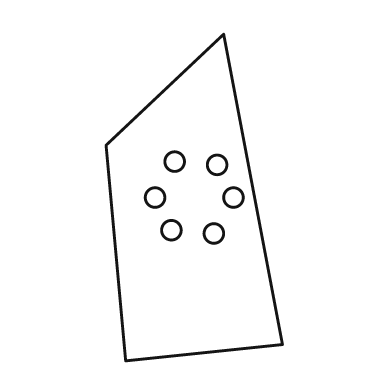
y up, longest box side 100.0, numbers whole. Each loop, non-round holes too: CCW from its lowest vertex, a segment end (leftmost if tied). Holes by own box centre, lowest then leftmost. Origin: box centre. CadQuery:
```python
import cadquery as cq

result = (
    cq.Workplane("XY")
    .moveTo(-21.0, -50.0)
    .lineTo(27.0, -45.0)
    .lineTo(9.0, 50.0)
    .lineTo(-27.0, 16.0)
    .close()
    .moveTo(6.0, -11.0)
    .circle(3.0)
    .moveTo(-7.0, -10.0)
    .circle(3.0)
    .moveTo(-12.0, 0.0)
    .circle(3.0)
    .moveTo(12.0, 0.0)
    .circle(3.0)
    .moveTo(7.0, 10.0)
    .circle(3.0)
    .moveTo(-6.0, 11.0)
    .circle(3.0)
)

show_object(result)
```